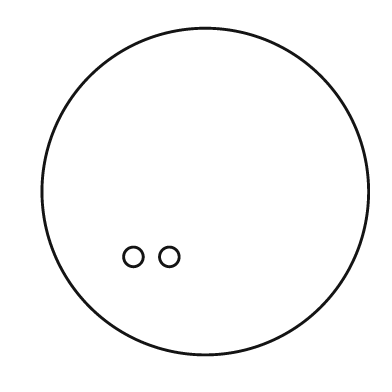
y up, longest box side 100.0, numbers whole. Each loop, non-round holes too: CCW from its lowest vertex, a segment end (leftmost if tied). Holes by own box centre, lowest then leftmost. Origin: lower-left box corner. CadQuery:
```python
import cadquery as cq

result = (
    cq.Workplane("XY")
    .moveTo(50.0, 50.0)
    .circle(50.0)
    .moveTo(28.0, 30.0)
    .circle(3.0)
    .moveTo(39.0, 30.0)
    .circle(3.0)
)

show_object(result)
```